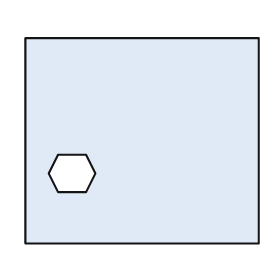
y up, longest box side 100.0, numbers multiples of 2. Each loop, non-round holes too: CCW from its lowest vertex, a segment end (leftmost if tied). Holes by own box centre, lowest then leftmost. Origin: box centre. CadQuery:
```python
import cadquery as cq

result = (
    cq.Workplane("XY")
    .moveTo(-50.0, -44.0)
    .lineTo(50.0, -44.0)
    .lineTo(50.0, 44.0)
    .lineTo(-50.0, 44.0)
    .close()
    .moveTo(-36.0, -22.0)
    .lineTo(-24.0, -22.0)
    .lineTo(-20.0, -14.0)
    .lineTo(-24.0, -6.0)
    .lineTo(-36.0, -6.0)
    .lineTo(-40.0, -14.0)
    .close()
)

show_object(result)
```